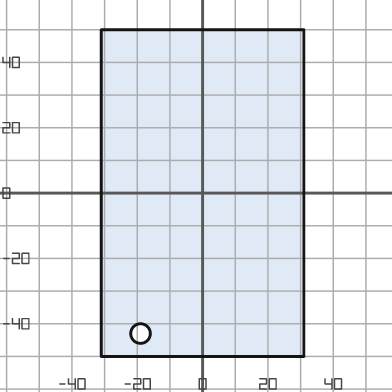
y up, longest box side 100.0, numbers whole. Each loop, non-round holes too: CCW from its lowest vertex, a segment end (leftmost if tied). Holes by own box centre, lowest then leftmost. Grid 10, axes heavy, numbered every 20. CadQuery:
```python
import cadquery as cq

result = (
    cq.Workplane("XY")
    .moveTo(-31.0, -50.0)
    .lineTo(31.0, -50.0)
    .lineTo(31.0, 50.0)
    .lineTo(-31.0, 50.0)
    .close()
    .moveTo(-19.0, -43.0)
    .circle(3.0)
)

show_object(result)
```